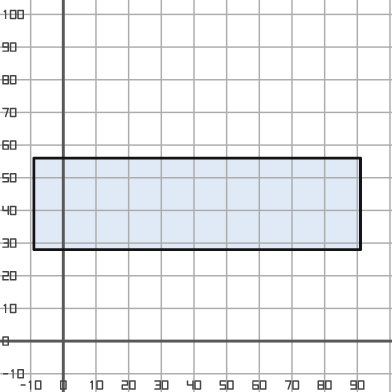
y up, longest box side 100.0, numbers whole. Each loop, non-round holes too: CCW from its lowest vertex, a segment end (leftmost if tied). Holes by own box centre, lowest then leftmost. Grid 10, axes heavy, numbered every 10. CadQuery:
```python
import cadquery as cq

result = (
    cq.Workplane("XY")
    .moveTo(-9.0, 28.0)
    .lineTo(91.0, 28.0)
    .lineTo(91.0, 56.0)
    .lineTo(-9.0, 56.0)
    .close()
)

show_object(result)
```